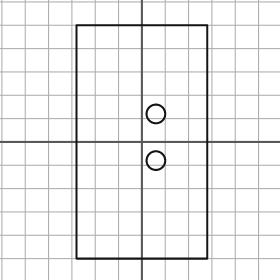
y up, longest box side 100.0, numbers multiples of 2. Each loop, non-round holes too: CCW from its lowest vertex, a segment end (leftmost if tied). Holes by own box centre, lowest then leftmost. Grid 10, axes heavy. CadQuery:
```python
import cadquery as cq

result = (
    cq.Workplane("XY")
    .moveTo(-28.0, -50.0)
    .lineTo(28.0, -50.0)
    .lineTo(28.0, 50.0)
    .lineTo(-28.0, 50.0)
    .close()
    .moveTo(6.0, -8.0)
    .circle(4.0)
    .moveTo(6.0, 12.0)
    .circle(4.0)
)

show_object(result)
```